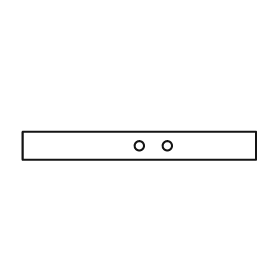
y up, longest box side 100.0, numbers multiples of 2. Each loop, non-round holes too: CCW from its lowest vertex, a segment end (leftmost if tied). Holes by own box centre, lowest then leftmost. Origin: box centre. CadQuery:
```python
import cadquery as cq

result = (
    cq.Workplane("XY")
    .moveTo(-50.0, -6.0)
    .lineTo(50.0, -6.0)
    .lineTo(50.0, 6.0)
    .lineTo(-50.0, 6.0)
    .close()
    .moveTo(0.0, 0.0)
    .circle(2.0)
    .moveTo(12.0, 0.0)
    .circle(2.0)
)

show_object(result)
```